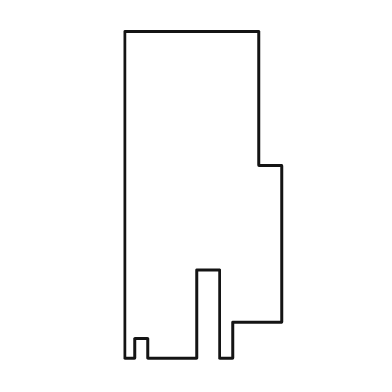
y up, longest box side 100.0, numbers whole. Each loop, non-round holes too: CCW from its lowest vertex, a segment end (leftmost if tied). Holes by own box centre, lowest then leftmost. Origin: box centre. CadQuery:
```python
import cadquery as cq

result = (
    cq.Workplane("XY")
    .moveTo(-24.0, -50.0)
    .lineTo(-21.0, -50.0)
    .lineTo(-21.0, -44.0)
    .lineTo(-17.0, -44.0)
    .lineTo(-17.0, -50.0)
    .lineTo(-2.0, -50.0)
    .lineTo(-2.0, -23.0)
    .lineTo(5.0, -23.0)
    .lineTo(5.0, -50.0)
    .lineTo(9.0, -50.0)
    .lineTo(9.0, -39.0)
    .lineTo(24.0, -39.0)
    .lineTo(24.0, 9.0)
    .lineTo(17.0, 9.0)
    .lineTo(17.0, 50.0)
    .lineTo(-24.0, 50.0)
    .close()
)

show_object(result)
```